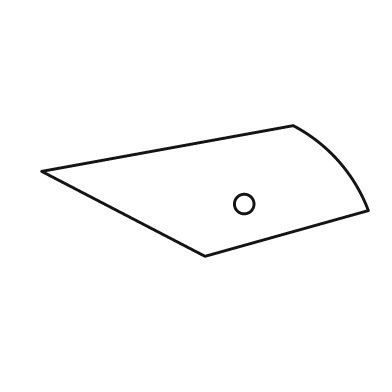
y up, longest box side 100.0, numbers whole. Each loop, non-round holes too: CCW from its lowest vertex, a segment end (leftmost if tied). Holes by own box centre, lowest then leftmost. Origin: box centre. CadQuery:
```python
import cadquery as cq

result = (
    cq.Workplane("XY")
    .moveTo(0.0, -20.0)
    .lineTo(50.0, -6.0)
    .threePointArc((41.0, 9.0), (27.0, 20.0))
    .lineTo(-50.0, 6.0)
    .close()
    .moveTo(12.0, -4.0)
    .circle(3.0)
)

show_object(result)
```